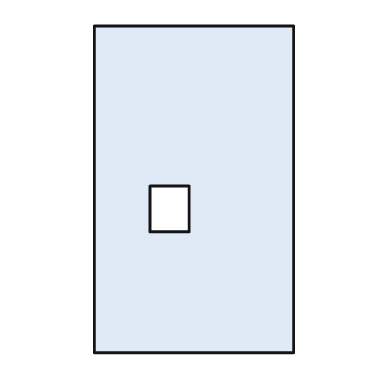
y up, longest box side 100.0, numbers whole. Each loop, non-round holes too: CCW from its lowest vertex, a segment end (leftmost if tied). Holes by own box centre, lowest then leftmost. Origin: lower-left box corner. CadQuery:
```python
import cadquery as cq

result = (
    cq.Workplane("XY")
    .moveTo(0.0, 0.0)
    .lineTo(61.0, 0.0)
    .lineTo(61.0, 100.0)
    .lineTo(0.0, 100.0)
    .close()
    .moveTo(17.0, 37.0)
    .lineTo(29.0, 37.0)
    .lineTo(29.0, 51.0)
    .lineTo(17.0, 51.0)
    .close()
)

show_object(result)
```